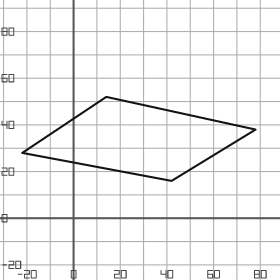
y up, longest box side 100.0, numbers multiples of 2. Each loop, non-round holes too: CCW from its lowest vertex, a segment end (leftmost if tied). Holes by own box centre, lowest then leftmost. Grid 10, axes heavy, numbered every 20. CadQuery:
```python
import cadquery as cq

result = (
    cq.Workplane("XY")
    .moveTo(42.0, 16.0)
    .lineTo(78.0, 38.0)
    .lineTo(14.0, 52.0)
    .lineTo(-22.0, 28.0)
    .close()
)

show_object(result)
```